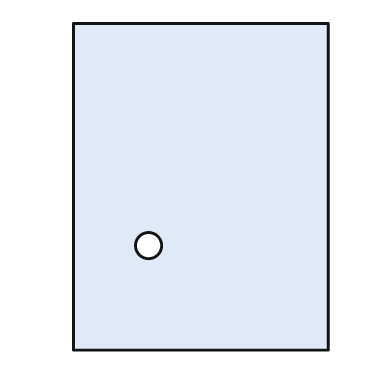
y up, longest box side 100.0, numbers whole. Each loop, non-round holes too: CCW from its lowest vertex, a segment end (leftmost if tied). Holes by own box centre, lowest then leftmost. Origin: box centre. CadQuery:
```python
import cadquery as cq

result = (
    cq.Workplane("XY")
    .moveTo(-39.0, -50.0)
    .lineTo(39.0, -50.0)
    .lineTo(39.0, 50.0)
    .lineTo(-39.0, 50.0)
    .close()
    .moveTo(-16.0, -18.0)
    .circle(4.0)
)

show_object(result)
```